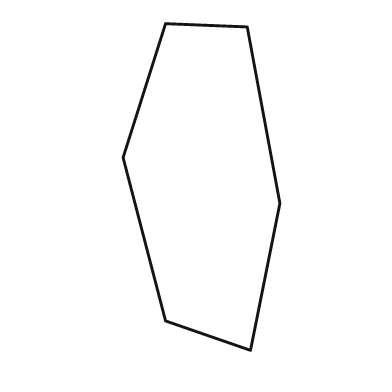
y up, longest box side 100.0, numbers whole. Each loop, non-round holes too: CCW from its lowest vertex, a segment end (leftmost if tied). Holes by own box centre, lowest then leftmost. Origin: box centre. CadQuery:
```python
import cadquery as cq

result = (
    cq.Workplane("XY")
    .moveTo(15.0, -50.0)
    .lineTo(24.0, -5.0)
    .lineTo(14.0, 49.0)
    .lineTo(-11.0, 50.0)
    .lineTo(-24.0, 9.0)
    .lineTo(-11.0, -41.0)
    .close()
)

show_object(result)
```